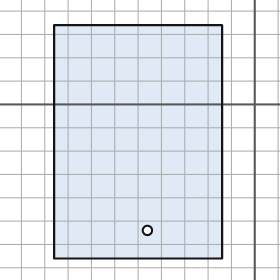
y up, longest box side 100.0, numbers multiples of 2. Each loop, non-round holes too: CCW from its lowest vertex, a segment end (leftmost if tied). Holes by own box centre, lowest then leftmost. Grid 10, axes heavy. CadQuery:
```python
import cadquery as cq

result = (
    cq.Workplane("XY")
    .moveTo(-86.0, -66.0)
    .lineTo(-14.0, -66.0)
    .lineTo(-14.0, 34.0)
    .lineTo(-86.0, 34.0)
    .close()
    .moveTo(-46.0, -54.0)
    .circle(2.0)
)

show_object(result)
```